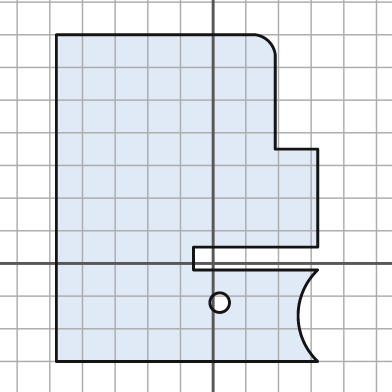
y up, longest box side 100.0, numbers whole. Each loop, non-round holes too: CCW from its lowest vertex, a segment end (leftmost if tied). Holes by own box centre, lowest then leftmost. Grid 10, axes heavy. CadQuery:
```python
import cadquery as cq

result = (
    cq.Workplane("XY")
    .moveTo(-48.0, -30.0)
    .lineTo(32.0, -30.0)
    .threePointArc((26.0, -16.0), (32.0, -2.0))
    .lineTo(-6.0, -2.0)
    .lineTo(-6.0, 5.0)
    .lineTo(32.0, 5.0)
    .lineTo(32.0, 35.0)
    .lineTo(19.0, 35.0)
    .lineTo(19.0, 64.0)
    .threePointArc((17.0, 68.0), (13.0, 70.0))
    .lineTo(-48.0, 70.0)
    .close()
    .moveTo(2.0, -12.0)
    .circle(3.0)
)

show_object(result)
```